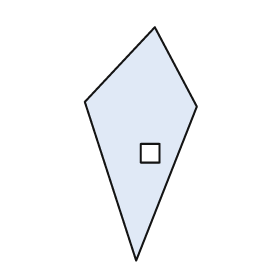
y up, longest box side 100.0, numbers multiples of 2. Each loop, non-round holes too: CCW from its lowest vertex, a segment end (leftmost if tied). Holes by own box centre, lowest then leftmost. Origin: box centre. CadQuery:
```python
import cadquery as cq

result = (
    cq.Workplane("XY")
    .moveTo(-2.0, -50.0)
    .lineTo(24.0, 16.0)
    .lineTo(6.0, 50.0)
    .lineTo(-24.0, 18.0)
    .close()
    .moveTo(0.0, -8.0)
    .lineTo(8.0, -8.0)
    .lineTo(8.0, 0.0)
    .lineTo(0.0, 0.0)
    .close()
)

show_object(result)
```